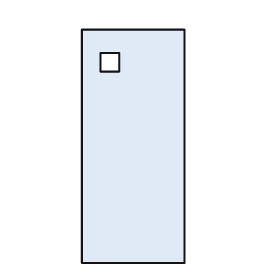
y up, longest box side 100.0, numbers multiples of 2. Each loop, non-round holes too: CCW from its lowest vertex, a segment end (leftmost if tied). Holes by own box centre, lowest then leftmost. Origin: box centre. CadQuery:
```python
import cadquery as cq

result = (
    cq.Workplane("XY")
    .moveTo(-22.0, -50.0)
    .lineTo(22.0, -50.0)
    .lineTo(22.0, 50.0)
    .lineTo(-22.0, 50.0)
    .close()
    .moveTo(-14.0, 32.0)
    .lineTo(-6.0, 32.0)
    .lineTo(-6.0, 40.0)
    .lineTo(-14.0, 40.0)
    .close()
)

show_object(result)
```